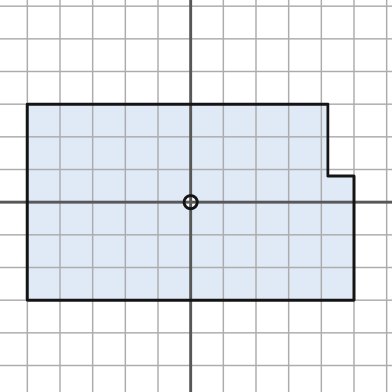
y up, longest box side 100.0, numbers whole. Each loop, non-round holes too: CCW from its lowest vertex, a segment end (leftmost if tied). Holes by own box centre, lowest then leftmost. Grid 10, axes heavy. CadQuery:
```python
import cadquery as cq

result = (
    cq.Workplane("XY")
    .moveTo(-50.0, -30.0)
    .lineTo(50.0, -30.0)
    .lineTo(50.0, 8.0)
    .lineTo(42.0, 8.0)
    .lineTo(42.0, 30.0)
    .lineTo(-50.0, 30.0)
    .close()
    .moveTo(0.0, 0.0)
    .circle(2.0)
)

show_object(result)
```